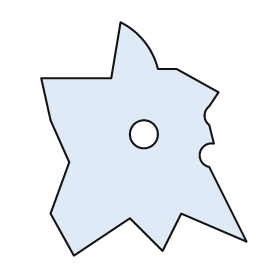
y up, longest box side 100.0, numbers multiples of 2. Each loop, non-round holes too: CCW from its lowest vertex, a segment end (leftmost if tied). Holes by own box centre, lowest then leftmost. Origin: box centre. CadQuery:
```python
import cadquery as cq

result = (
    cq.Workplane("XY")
    .moveTo(-30.0, -50.0)
    .lineTo(-6.0, -34.0)
    .lineTo(8.0, -48.0)
    .lineTo(16.0, -32.0)
    .lineTo(44.0, -44.0)
    .lineTo(28.0, -12.0)
    .threePointArc((24.0, -6.0), (30.0, -2.0))
    .lineTo(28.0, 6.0)
    .threePointArc((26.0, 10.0), (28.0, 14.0))
    .lineTo(32.0, 20.0)
    .lineTo(14.0, 30.0)
    .lineTo(6.0, 30.0)
    .threePointArc((0.0, 42.0), (-10.0, 50.0))
    .lineTo(-14.0, 26.0)
    .lineTo(-44.0, 26.0)
    .lineTo(-40.0, 8.0)
    .lineTo(-32.0, -10.0)
    .lineTo(-40.0, -32.0)
    .close()
    .moveTo(0.0, 2.0)
    .circle(6.0)
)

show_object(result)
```